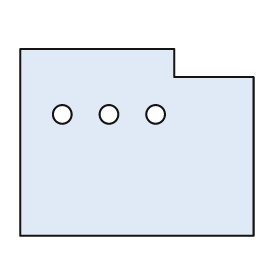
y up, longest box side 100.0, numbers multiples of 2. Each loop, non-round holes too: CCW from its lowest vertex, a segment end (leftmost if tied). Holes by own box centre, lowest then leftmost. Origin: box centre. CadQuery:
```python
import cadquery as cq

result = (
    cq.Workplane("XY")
    .moveTo(-50.0, -40.0)
    .lineTo(50.0, -40.0)
    .lineTo(50.0, 28.0)
    .lineTo(16.0, 28.0)
    .lineTo(16.0, 40.0)
    .lineTo(-50.0, 40.0)
    .close()
    .moveTo(-32.0, 12.0)
    .circle(4.0)
    .moveTo(-12.0, 12.0)
    .circle(4.0)
    .moveTo(8.0, 12.0)
    .circle(4.0)
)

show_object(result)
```